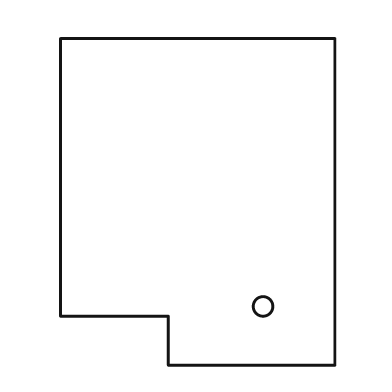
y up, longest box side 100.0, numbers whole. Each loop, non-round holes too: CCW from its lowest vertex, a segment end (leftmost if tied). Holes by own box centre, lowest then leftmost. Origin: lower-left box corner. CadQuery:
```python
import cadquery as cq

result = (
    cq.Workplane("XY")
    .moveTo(33.0, 0.0)
    .lineTo(84.0, 0.0)
    .lineTo(84.0, 100.0)
    .lineTo(0.0, 100.0)
    .lineTo(0.0, 15.0)
    .lineTo(33.0, 15.0)
    .close()
    .moveTo(62.0, 18.0)
    .circle(3.0)
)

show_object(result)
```